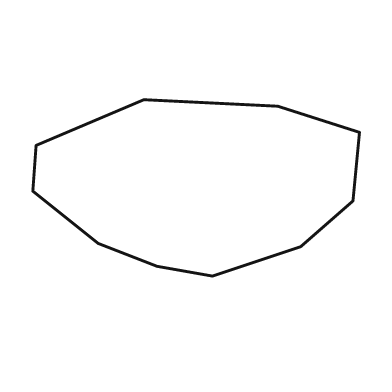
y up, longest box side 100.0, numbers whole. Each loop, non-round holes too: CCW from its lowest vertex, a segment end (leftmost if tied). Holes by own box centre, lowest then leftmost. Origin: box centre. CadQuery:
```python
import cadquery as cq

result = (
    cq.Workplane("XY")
    .moveTo(5.0, -27.0)
    .lineTo(32.0, -18.0)
    .lineTo(48.0, -4.0)
    .lineTo(50.0, 17.0)
    .lineTo(25.0, 25.0)
    .lineTo(-16.0, 27.0)
    .lineTo(-49.0, 13.0)
    .lineTo(-50.0, -1.0)
    .lineTo(-30.0, -17.0)
    .lineTo(-12.0, -24.0)
    .close()
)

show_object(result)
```